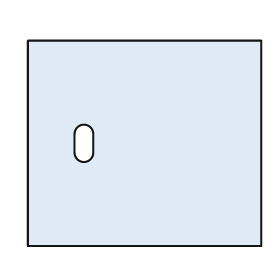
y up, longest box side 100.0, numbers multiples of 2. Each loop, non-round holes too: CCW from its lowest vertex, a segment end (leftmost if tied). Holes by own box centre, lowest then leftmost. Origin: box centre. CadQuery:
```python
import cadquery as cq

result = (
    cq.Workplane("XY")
    .moveTo(-50.0, -44.0)
    .lineTo(50.0, -44.0)
    .lineTo(50.0, 44.0)
    .lineTo(-50.0, 44.0)
    .close()
    .moveTo(-30.0, -4.0)
    .threePointArc((-26.0, -8.0), (-22.0, -4.0))
    .lineTo(-22.0, 4.0)
    .threePointArc((-26.0, 8.0), (-30.0, 4.0))
    .close()
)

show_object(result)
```